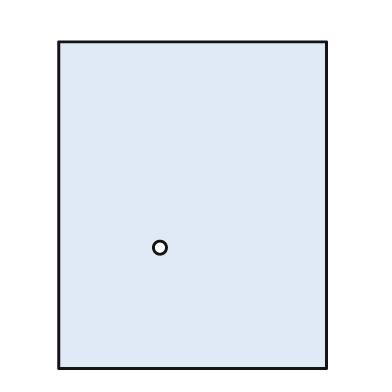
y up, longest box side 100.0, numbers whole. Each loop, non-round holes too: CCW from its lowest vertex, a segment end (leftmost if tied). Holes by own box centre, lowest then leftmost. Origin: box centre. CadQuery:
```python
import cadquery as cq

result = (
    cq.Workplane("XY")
    .moveTo(-41.0, -50.0)
    .lineTo(41.0, -50.0)
    .lineTo(41.0, 50.0)
    .lineTo(-41.0, 50.0)
    .close()
    .moveTo(-10.0, -13.0)
    .circle(2.0)
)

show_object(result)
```